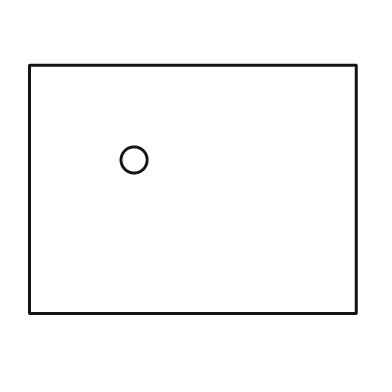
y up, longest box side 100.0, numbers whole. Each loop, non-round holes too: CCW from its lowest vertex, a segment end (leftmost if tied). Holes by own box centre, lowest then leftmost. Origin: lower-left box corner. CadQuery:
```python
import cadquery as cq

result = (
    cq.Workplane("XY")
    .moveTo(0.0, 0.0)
    .lineTo(100.0, 0.0)
    .lineTo(100.0, 76.0)
    .lineTo(0.0, 76.0)
    .close()
    .moveTo(32.0, 47.0)
    .circle(4.0)
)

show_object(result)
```